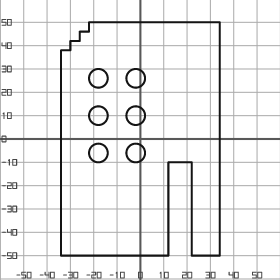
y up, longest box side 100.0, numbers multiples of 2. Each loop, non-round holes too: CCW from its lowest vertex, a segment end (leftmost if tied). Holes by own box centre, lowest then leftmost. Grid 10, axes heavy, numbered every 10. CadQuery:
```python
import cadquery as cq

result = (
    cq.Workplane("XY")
    .moveTo(-34.0, -50.0)
    .lineTo(12.0, -50.0)
    .lineTo(12.0, -10.0)
    .lineTo(22.0, -10.0)
    .lineTo(22.0, -50.0)
    .lineTo(34.0, -50.0)
    .lineTo(34.0, 50.0)
    .lineTo(-22.0, 50.0)
    .lineTo(-22.0, 46.0)
    .lineTo(-26.0, 46.0)
    .lineTo(-26.0, 42.0)
    .lineTo(-30.0, 42.0)
    .lineTo(-30.0, 38.0)
    .lineTo(-34.0, 38.0)
    .close()
    .moveTo(-18.0, -6.0)
    .circle(4.0)
    .moveTo(-2.0, -6.0)
    .circle(4.0)
    .moveTo(-18.0, 10.0)
    .circle(4.0)
    .moveTo(-2.0, 10.0)
    .circle(4.0)
    .moveTo(-18.0, 26.0)
    .circle(4.0)
    .moveTo(-2.0, 26.0)
    .circle(4.0)
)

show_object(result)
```